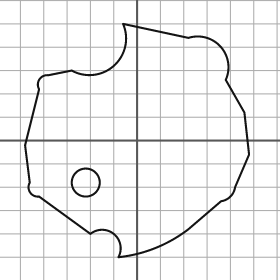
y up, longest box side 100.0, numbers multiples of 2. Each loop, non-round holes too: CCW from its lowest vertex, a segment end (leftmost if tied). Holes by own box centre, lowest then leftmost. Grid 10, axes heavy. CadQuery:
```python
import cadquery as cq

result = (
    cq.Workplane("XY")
    .moveTo(-8.0, -50.0)
    .threePointArc((8.0, -46.0), (22.0, -38.0))
    .lineTo(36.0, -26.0)
    .threePointArc((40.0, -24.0), (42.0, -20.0))
    .lineTo(48.0, -6.0)
    .lineTo(46.0, 12.0)
    .lineTo(38.0, 26.0)
    .threePointArc((36.0, 40.0), (22.0, 44.0))
    .lineTo(-6.0, 50.0)
    .threePointArc((-10.0, 32.0), (-28.0, 30.0))
    .lineTo(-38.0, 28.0)
    .threePointArc((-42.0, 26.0), (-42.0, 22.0))
    .lineTo(-48.0, -2.0)
    .lineTo(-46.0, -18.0)
    .threePointArc((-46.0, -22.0), (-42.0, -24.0))
    .lineTo(-20.0, -40.0)
    .threePointArc((-10.0, -40.0), (-8.0, -50.0))
    .close()
    .moveTo(-22.0, -18.0)
    .circle(6.0)
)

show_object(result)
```